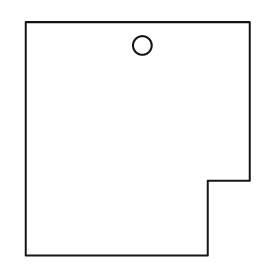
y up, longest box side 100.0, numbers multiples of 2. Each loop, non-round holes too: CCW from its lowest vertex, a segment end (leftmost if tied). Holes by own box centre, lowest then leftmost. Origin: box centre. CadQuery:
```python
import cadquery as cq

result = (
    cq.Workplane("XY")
    .moveTo(-48.0, -50.0)
    .lineTo(30.0, -50.0)
    .lineTo(30.0, -18.0)
    .lineTo(48.0, -18.0)
    .lineTo(48.0, 50.0)
    .lineTo(-48.0, 50.0)
    .close()
    .moveTo(2.0, 40.0)
    .circle(4.0)
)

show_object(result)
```